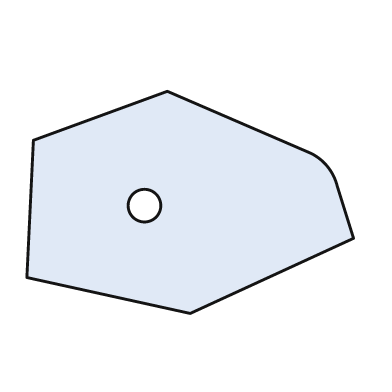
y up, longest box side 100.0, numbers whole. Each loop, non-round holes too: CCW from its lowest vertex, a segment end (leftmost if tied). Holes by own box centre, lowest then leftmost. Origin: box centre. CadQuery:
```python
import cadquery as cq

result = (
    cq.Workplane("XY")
    .moveTo(0.0, -34.0)
    .lineTo(50.0, -11.0)
    .lineTo(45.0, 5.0)
    .threePointArc((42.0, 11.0), (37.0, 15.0))
    .lineTo(-7.0, 34.0)
    .lineTo(-48.0, 19.0)
    .lineTo(-50.0, -23.0)
    .close()
    .moveTo(-14.0, -1.0)
    .circle(5.0)
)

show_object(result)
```